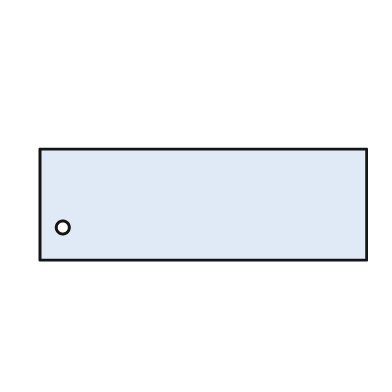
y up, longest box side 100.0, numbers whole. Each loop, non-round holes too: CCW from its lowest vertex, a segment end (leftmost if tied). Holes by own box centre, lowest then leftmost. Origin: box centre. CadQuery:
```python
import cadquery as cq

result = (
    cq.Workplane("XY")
    .moveTo(-50.0, -17.0)
    .lineTo(50.0, -17.0)
    .lineTo(50.0, 17.0)
    .lineTo(-50.0, 17.0)
    .close()
    .moveTo(-43.0, -7.0)
    .circle(2.0)
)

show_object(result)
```